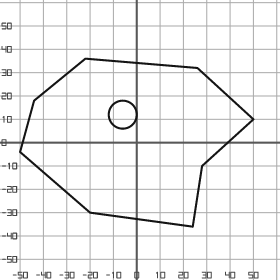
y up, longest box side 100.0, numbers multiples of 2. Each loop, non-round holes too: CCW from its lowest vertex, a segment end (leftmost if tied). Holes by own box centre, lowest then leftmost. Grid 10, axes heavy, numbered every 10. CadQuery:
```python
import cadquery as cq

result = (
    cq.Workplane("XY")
    .moveTo(24.0, -36.0)
    .lineTo(28.0, -10.0)
    .lineTo(50.0, 10.0)
    .lineTo(26.0, 32.0)
    .lineTo(-22.0, 36.0)
    .lineTo(-44.0, 18.0)
    .lineTo(-50.0, -4.0)
    .lineTo(-20.0, -30.0)
    .close()
    .moveTo(-6.0, 12.0)
    .circle(6.0)
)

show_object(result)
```